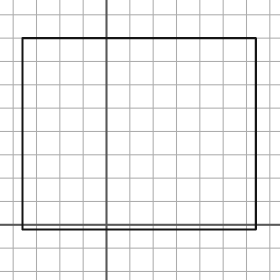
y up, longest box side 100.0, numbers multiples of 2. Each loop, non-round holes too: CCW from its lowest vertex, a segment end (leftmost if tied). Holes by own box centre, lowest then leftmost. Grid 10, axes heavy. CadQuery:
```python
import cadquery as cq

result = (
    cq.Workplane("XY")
    .moveTo(-36.0, -2.0)
    .lineTo(64.0, -2.0)
    .lineTo(64.0, 80.0)
    .lineTo(-36.0, 80.0)
    .close()
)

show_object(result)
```